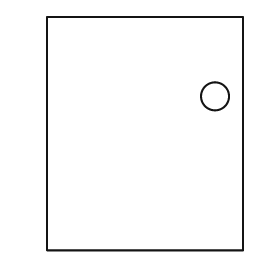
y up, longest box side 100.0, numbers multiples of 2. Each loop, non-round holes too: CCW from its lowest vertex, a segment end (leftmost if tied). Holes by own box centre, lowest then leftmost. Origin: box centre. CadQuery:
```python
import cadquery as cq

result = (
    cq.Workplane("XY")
    .moveTo(-42.0, -50.0)
    .lineTo(42.0, -50.0)
    .lineTo(42.0, 50.0)
    .lineTo(-42.0, 50.0)
    .close()
    .moveTo(30.0, 16.0)
    .circle(6.0)
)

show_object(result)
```